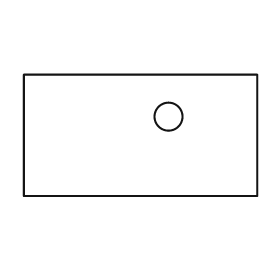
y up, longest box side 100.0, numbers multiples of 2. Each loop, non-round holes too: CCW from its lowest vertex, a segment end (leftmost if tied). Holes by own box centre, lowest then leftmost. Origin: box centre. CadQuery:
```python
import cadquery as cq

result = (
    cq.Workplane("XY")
    .moveTo(-50.0, -26.0)
    .lineTo(50.0, -26.0)
    .lineTo(50.0, 26.0)
    .lineTo(-50.0, 26.0)
    .close()
    .moveTo(12.0, 8.0)
    .circle(6.0)
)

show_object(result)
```